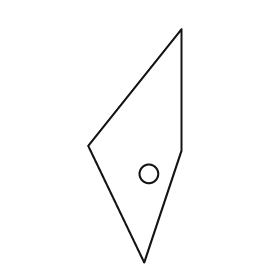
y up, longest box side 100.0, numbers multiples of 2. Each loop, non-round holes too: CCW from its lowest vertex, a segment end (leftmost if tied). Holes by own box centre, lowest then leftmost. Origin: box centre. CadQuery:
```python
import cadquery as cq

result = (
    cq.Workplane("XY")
    .moveTo(4.0, -50.0)
    .lineTo(20.0, -2.0)
    .lineTo(20.0, 50.0)
    .lineTo(-20.0, 0.0)
    .close()
    .moveTo(6.0, -12.0)
    .circle(4.0)
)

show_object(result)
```